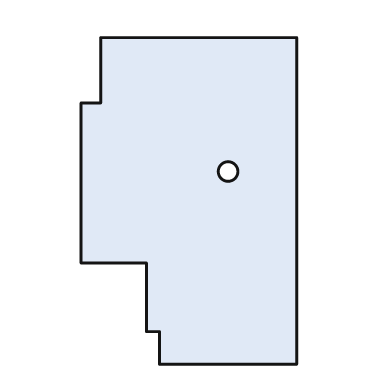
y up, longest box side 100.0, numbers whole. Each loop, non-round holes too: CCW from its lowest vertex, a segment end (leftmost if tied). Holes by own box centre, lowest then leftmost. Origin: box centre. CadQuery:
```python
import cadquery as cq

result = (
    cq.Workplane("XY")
    .moveTo(-9.0, -50.0)
    .lineTo(33.0, -50.0)
    .lineTo(33.0, 50.0)
    .lineTo(-27.0, 50.0)
    .lineTo(-27.0, 30.0)
    .lineTo(-33.0, 30.0)
    .lineTo(-33.0, -19.0)
    .lineTo(-13.0, -19.0)
    .lineTo(-13.0, -40.0)
    .lineTo(-9.0, -40.0)
    .close()
    .moveTo(12.0, 9.0)
    .circle(3.0)
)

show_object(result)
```